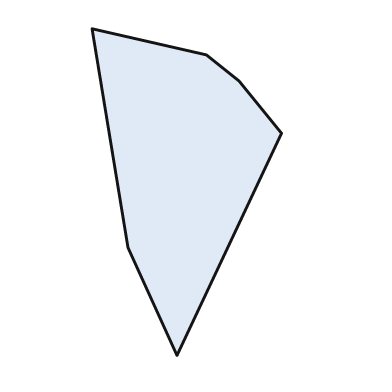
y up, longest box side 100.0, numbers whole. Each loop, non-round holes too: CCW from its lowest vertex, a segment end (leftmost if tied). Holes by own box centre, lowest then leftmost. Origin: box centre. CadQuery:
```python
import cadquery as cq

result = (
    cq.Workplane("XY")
    .moveTo(-3.0, -50.0)
    .lineTo(29.0, 18.0)
    .lineTo(16.0, 34.0)
    .lineTo(6.0, 42.0)
    .lineTo(-29.0, 50.0)
    .lineTo(-18.0, -17.0)
    .close()
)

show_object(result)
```